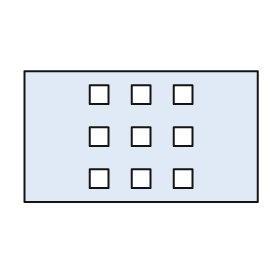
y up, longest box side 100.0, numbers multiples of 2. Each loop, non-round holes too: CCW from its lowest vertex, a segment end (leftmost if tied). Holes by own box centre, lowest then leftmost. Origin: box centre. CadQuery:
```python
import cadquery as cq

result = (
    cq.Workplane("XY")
    .moveTo(-50.0, -28.0)
    .lineTo(50.0, -28.0)
    .lineTo(50.0, 28.0)
    .lineTo(-50.0, 28.0)
    .close()
    .moveTo(-22.0, -22.0)
    .lineTo(-14.0, -22.0)
    .lineTo(-14.0, -14.0)
    .lineTo(-22.0, -14.0)
    .close()
    .moveTo(-4.0, -22.0)
    .lineTo(4.0, -22.0)
    .lineTo(4.0, -14.0)
    .lineTo(-4.0, -14.0)
    .close()
    .moveTo(14.0, -22.0)
    .lineTo(22.0, -22.0)
    .lineTo(22.0, -14.0)
    .lineTo(14.0, -14.0)
    .close()
    .moveTo(-22.0, -4.0)
    .lineTo(-14.0, -4.0)
    .lineTo(-14.0, 4.0)
    .lineTo(-22.0, 4.0)
    .close()
    .moveTo(-4.0, -4.0)
    .lineTo(4.0, -4.0)
    .lineTo(4.0, 4.0)
    .lineTo(-4.0, 4.0)
    .close()
    .moveTo(14.0, -4.0)
    .lineTo(22.0, -4.0)
    .lineTo(22.0, 4.0)
    .lineTo(14.0, 4.0)
    .close()
    .moveTo(-22.0, 14.0)
    .lineTo(-14.0, 14.0)
    .lineTo(-14.0, 22.0)
    .lineTo(-22.0, 22.0)
    .close()
    .moveTo(-4.0, 14.0)
    .lineTo(4.0, 14.0)
    .lineTo(4.0, 22.0)
    .lineTo(-4.0, 22.0)
    .close()
    .moveTo(14.0, 14.0)
    .lineTo(22.0, 14.0)
    .lineTo(22.0, 22.0)
    .lineTo(14.0, 22.0)
    .close()
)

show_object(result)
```